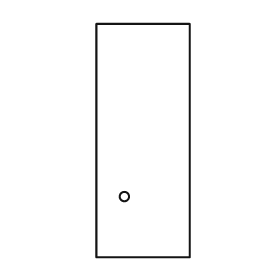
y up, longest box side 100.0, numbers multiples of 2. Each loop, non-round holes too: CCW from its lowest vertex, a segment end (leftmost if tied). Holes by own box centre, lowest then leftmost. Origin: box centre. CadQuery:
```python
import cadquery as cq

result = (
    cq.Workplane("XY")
    .moveTo(-20.0, -50.0)
    .lineTo(20.0, -50.0)
    .lineTo(20.0, 50.0)
    .lineTo(-20.0, 50.0)
    .close()
    .moveTo(-8.0, -24.0)
    .circle(2.0)
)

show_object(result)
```